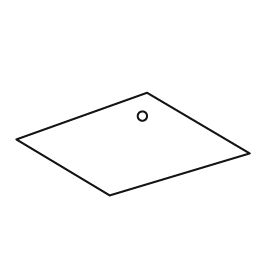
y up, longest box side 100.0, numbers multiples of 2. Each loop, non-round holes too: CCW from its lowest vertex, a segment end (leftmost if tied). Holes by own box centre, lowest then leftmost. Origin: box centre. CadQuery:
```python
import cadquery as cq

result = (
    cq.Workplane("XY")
    .moveTo(-10.0, -22.0)
    .lineTo(50.0, -4.0)
    .lineTo(6.0, 22.0)
    .lineTo(-50.0, 2.0)
    .close()
    .moveTo(4.0, 12.0)
    .circle(2.0)
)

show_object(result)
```